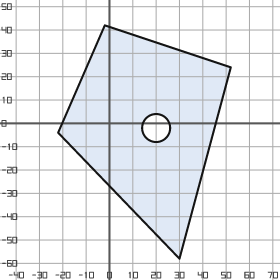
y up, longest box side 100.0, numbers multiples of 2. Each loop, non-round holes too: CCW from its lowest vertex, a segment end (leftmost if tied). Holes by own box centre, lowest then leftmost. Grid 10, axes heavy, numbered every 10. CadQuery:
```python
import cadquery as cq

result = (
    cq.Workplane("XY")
    .moveTo(30.0, -58.0)
    .lineTo(52.0, 24.0)
    .lineTo(-2.0, 42.0)
    .lineTo(-22.0, -4.0)
    .close()
    .moveTo(20.0, -2.0)
    .circle(6.0)
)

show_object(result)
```